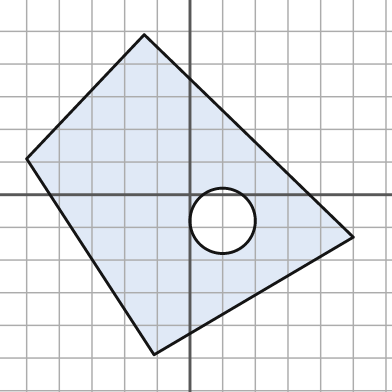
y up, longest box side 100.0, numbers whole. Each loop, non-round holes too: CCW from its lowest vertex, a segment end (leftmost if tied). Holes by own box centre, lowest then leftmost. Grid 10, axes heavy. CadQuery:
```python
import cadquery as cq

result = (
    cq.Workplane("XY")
    .moveTo(-11.0, -49.0)
    .lineTo(50.0, -13.0)
    .lineTo(-14.0, 49.0)
    .lineTo(-50.0, 11.0)
    .close()
    .moveTo(10.0, -8.0)
    .circle(10.0)
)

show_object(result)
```